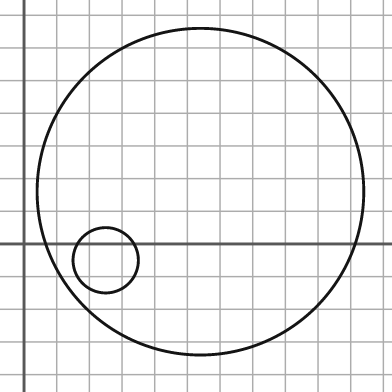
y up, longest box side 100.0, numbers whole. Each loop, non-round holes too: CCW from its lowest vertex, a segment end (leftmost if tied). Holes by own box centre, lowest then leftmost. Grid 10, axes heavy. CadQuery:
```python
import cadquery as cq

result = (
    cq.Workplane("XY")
    .moveTo(54.0, 16.0)
    .circle(50.0)
    .moveTo(25.0, -5.0)
    .circle(10.0)
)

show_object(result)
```